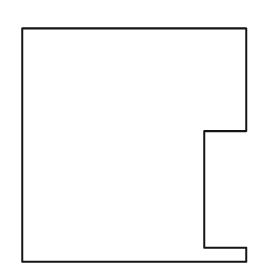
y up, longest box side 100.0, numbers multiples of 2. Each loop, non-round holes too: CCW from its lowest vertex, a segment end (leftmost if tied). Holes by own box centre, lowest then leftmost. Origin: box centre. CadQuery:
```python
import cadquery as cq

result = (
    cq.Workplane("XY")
    .moveTo(-48.0, -50.0)
    .lineTo(48.0, -50.0)
    .lineTo(48.0, -44.0)
    .lineTo(30.0, -44.0)
    .lineTo(30.0, 6.0)
    .lineTo(48.0, 6.0)
    .lineTo(48.0, 50.0)
    .lineTo(-48.0, 50.0)
    .close()
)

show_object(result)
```